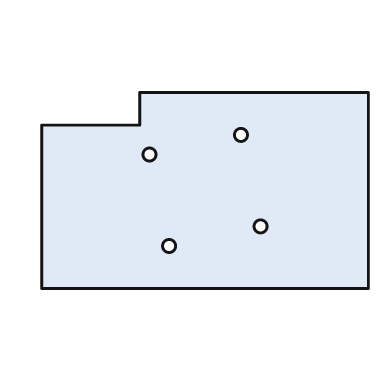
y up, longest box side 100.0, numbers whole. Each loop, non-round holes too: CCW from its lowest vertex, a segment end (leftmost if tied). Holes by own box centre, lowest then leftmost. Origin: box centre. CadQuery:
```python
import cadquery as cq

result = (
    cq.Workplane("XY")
    .moveTo(-50.0, -30.0)
    .lineTo(50.0, -30.0)
    .lineTo(50.0, 30.0)
    .lineTo(-20.0, 30.0)
    .lineTo(-20.0, 20.0)
    .lineTo(-50.0, 20.0)
    .close()
    .moveTo(-11.0, -17.0)
    .circle(2.0)
    .moveTo(17.0, -11.0)
    .circle(2.0)
    .moveTo(-17.0, 11.0)
    .circle(2.0)
    .moveTo(11.0, 17.0)
    .circle(2.0)
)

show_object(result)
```